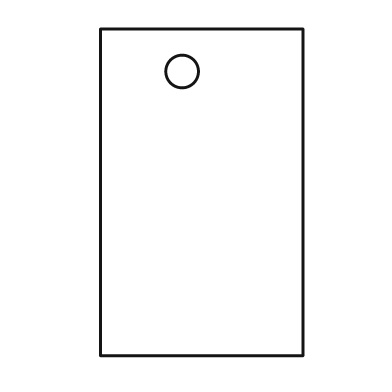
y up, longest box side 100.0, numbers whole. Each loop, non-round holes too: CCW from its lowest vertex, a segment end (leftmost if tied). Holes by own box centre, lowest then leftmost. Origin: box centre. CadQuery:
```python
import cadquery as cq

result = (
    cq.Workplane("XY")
    .moveTo(-31.0, -50.0)
    .lineTo(31.0, -50.0)
    .lineTo(31.0, 50.0)
    .lineTo(-31.0, 50.0)
    .close()
    .moveTo(-6.0, 37.0)
    .circle(5.0)
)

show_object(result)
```